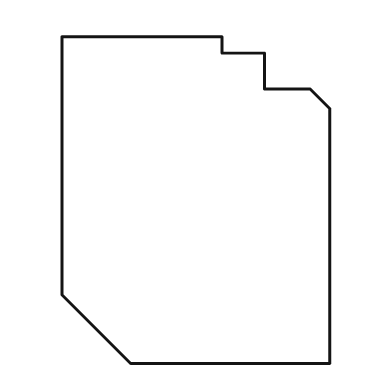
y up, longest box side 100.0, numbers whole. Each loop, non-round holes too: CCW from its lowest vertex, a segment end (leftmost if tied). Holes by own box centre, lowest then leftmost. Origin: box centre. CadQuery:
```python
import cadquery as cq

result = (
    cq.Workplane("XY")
    .moveTo(-20.0, -50.0)
    .lineTo(41.0, -50.0)
    .lineTo(41.0, 28.0)
    .lineTo(35.0, 34.0)
    .lineTo(21.0, 34.0)
    .lineTo(21.0, 45.0)
    .lineTo(8.0, 45.0)
    .lineTo(8.0, 50.0)
    .lineTo(-41.0, 50.0)
    .lineTo(-41.0, -29.0)
    .close()
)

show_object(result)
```